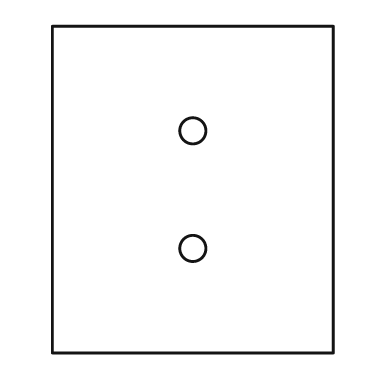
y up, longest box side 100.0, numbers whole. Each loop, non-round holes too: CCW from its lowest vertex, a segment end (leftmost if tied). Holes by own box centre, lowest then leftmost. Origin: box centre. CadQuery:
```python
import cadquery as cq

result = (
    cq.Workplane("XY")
    .moveTo(-43.0, -50.0)
    .lineTo(43.0, -50.0)
    .lineTo(43.0, 50.0)
    .lineTo(-43.0, 50.0)
    .close()
    .moveTo(0.0, -18.0)
    .circle(4.0)
    .moveTo(0.0, 18.0)
    .circle(4.0)
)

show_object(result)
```